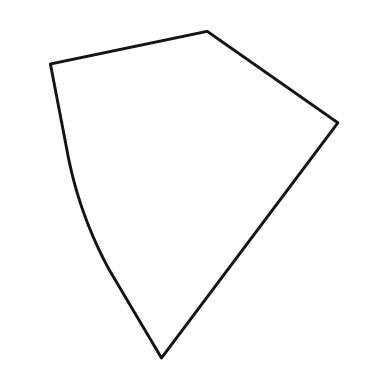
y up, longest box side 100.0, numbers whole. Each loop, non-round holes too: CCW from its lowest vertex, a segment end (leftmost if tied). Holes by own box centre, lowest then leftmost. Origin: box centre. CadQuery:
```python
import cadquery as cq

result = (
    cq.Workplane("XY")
    .moveTo(-10.0, -50.0)
    .lineTo(44.0, 22.0)
    .lineTo(4.0, 50.0)
    .lineTo(-44.0, 40.0)
    .lineTo(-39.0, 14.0)
    .threePointArc((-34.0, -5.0), (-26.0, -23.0))
    .close()
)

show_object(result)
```